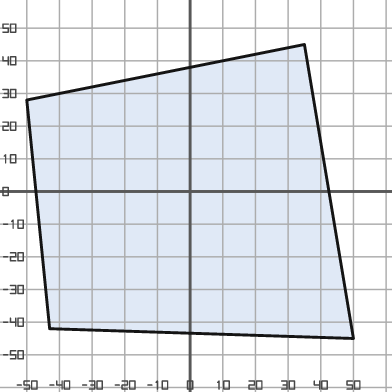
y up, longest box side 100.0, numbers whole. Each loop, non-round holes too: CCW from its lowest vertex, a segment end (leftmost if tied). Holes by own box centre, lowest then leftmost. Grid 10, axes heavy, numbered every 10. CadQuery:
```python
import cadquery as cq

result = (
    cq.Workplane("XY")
    .moveTo(50.0, -45.0)
    .lineTo(35.0, 45.0)
    .lineTo(-50.0, 28.0)
    .lineTo(-43.0, -42.0)
    .close()
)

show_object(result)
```